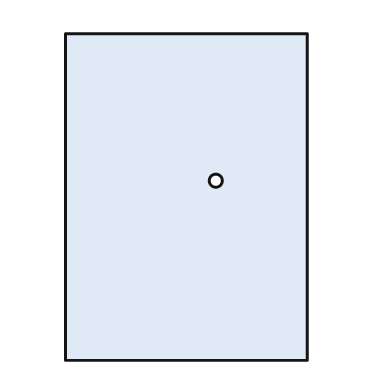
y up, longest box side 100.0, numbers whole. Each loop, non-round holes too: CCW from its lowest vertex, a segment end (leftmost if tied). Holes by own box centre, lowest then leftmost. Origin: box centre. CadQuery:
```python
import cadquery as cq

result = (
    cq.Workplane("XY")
    .moveTo(-37.0, -50.0)
    .lineTo(37.0, -50.0)
    .lineTo(37.0, 50.0)
    .lineTo(-37.0, 50.0)
    .close()
    .moveTo(9.0, 5.0)
    .circle(2.0)
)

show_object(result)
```